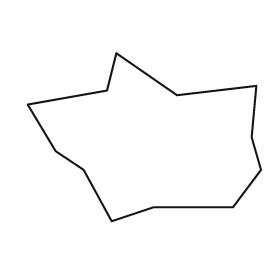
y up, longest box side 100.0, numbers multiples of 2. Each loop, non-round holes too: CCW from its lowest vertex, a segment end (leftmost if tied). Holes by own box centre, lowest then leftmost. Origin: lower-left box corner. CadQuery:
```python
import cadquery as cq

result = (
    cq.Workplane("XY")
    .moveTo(36.0, 0.0)
    .lineTo(54.0, 6.0)
    .lineTo(88.0, 6.0)
    .lineTo(100.0, 22.0)
    .lineTo(96.0, 36.0)
    .lineTo(98.0, 58.0)
    .lineTo(64.0, 54.0)
    .lineTo(38.0, 72.0)
    .lineTo(34.0, 56.0)
    .lineTo(0.0, 50.0)
    .lineTo(12.0, 30.0)
    .lineTo(24.0, 22.0)
    .close()
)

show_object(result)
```